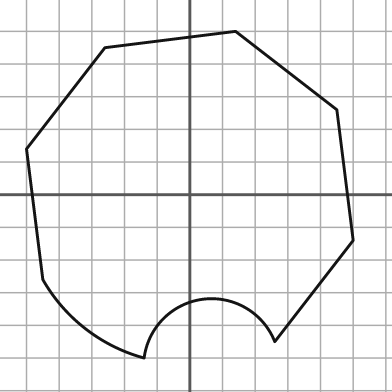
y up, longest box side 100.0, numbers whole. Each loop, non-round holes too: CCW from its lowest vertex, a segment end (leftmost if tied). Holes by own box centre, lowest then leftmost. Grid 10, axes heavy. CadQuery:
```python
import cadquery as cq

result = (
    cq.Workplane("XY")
    .moveTo(-14.0, -50.0)
    .threePointArc((4.0, -32.0), (26.0, -45.0))
    .lineTo(50.0, -14.0)
    .lineTo(45.0, 26.0)
    .lineTo(14.0, 50.0)
    .lineTo(-26.0, 45.0)
    .lineTo(-50.0, 14.0)
    .lineTo(-45.0, -26.0)
    .threePointArc((-32.0, -41.0), (-14.0, -50.0))
    .close()
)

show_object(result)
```